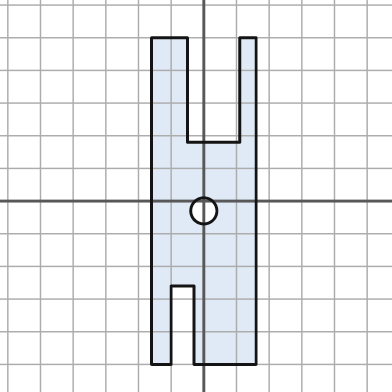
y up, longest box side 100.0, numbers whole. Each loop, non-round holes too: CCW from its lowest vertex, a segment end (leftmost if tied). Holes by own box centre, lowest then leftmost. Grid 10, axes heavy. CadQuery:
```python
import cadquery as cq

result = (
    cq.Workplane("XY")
    .moveTo(-16.0, -50.0)
    .lineTo(-10.0, -50.0)
    .lineTo(-10.0, -26.0)
    .lineTo(-3.0, -26.0)
    .lineTo(-3.0, -50.0)
    .lineTo(16.0, -50.0)
    .lineTo(16.0, 50.0)
    .lineTo(11.0, 50.0)
    .lineTo(11.0, 18.0)
    .lineTo(-5.0, 18.0)
    .lineTo(-5.0, 50.0)
    .lineTo(-16.0, 50.0)
    .close()
    .moveTo(0.0, -3.0)
    .circle(4.0)
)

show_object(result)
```